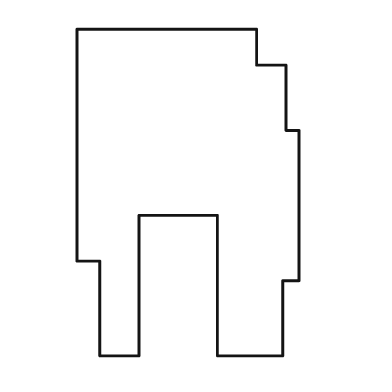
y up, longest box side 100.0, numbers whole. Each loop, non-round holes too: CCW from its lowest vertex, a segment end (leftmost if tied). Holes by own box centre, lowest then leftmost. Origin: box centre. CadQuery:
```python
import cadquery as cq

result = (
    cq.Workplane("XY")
    .moveTo(-27.0, -50.0)
    .lineTo(-15.0, -50.0)
    .lineTo(-15.0, -7.0)
    .lineTo(9.0, -7.0)
    .lineTo(9.0, -50.0)
    .lineTo(29.0, -50.0)
    .lineTo(29.0, -27.0)
    .lineTo(34.0, -27.0)
    .lineTo(34.0, 19.0)
    .lineTo(30.0, 19.0)
    .lineTo(30.0, 39.0)
    .lineTo(21.0, 39.0)
    .lineTo(21.0, 50.0)
    .lineTo(-34.0, 50.0)
    .lineTo(-34.0, -21.0)
    .lineTo(-27.0, -21.0)
    .close()
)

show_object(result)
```